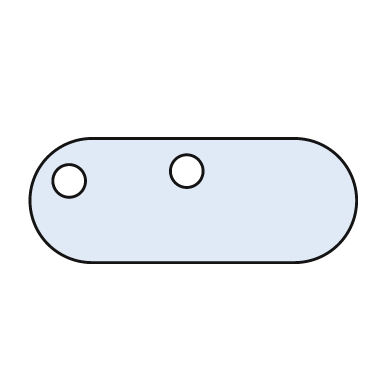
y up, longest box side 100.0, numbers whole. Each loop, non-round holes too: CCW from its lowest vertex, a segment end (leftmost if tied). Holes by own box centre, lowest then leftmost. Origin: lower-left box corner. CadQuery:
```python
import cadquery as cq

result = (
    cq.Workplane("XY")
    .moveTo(19.0, 0.0)
    .lineTo(81.0, 0.0)
    .threePointArc((100.0, 19.0), (81.0, 38.0))
    .lineTo(19.0, 38.0)
    .threePointArc((0.0, 19.0), (19.0, 0.0))
    .close()
    .moveTo(12.0, 25.0)
    .circle(5.0)
    .moveTo(48.0, 28.0)
    .circle(5.0)
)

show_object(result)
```